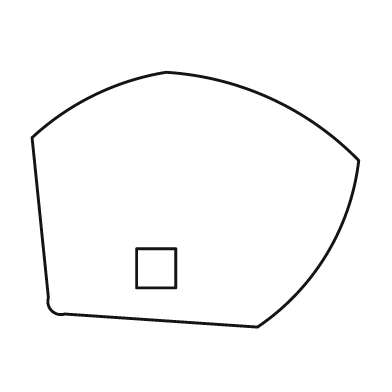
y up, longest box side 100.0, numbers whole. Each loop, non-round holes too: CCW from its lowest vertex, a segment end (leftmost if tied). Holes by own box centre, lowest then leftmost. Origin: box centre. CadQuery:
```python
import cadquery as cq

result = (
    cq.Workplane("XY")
    .moveTo(19.0, -39.0)
    .threePointArc((40.0, -17.0), (50.0, 12.0))
    .threePointArc((23.0, 31.0), (-9.0, 39.0))
    .threePointArc((-31.0, 32.0), (-50.0, 19.0))
    .lineTo(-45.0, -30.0)
    .threePointArc((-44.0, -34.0), (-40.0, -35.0))
    .close()
    .moveTo(-18.0, -27.0)
    .lineTo(-6.0, -27.0)
    .lineTo(-6.0, -15.0)
    .lineTo(-18.0, -15.0)
    .close()
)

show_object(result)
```